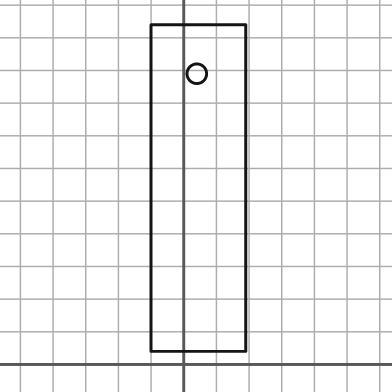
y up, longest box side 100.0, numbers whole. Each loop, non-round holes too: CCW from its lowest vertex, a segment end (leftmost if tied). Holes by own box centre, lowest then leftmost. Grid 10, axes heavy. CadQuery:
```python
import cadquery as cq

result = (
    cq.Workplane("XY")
    .moveTo(-10.0, 4.0)
    .lineTo(19.0, 4.0)
    .lineTo(19.0, 104.0)
    .lineTo(-10.0, 104.0)
    .close()
    .moveTo(4.0, 89.0)
    .circle(3.0)
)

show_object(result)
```